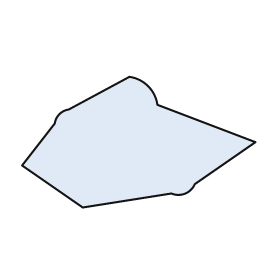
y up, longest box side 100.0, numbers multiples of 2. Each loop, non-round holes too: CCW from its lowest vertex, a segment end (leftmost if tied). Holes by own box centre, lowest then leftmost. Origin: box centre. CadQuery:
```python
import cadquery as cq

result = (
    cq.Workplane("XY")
    .moveTo(-24.0, -28.0)
    .lineTo(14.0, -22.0)
    .threePointArc((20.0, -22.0), (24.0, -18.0))
    .lineTo(50.0, 0.0)
    .lineTo(8.0, 16.0)
    .threePointArc((4.0, 24.0), (-4.0, 28.0))
    .lineTo(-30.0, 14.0)
    .threePointArc((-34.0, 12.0), (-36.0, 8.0))
    .lineTo(-50.0, -10.0)
    .close()
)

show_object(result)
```